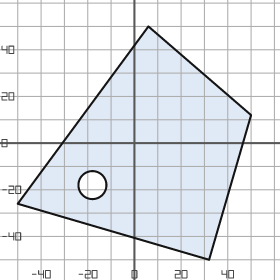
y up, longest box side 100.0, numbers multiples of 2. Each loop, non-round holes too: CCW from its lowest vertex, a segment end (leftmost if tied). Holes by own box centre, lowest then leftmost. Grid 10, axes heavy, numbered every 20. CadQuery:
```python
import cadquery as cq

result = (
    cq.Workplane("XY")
    .moveTo(32.0, -50.0)
    .lineTo(50.0, 12.0)
    .lineTo(6.0, 50.0)
    .lineTo(-50.0, -26.0)
    .close()
    .moveTo(-18.0, -18.0)
    .circle(6.0)
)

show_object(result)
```